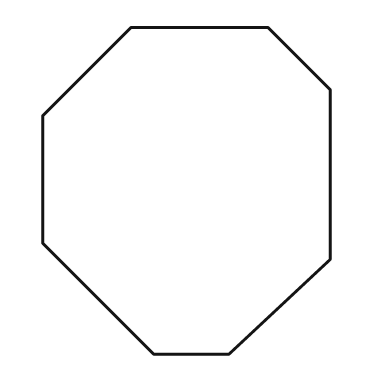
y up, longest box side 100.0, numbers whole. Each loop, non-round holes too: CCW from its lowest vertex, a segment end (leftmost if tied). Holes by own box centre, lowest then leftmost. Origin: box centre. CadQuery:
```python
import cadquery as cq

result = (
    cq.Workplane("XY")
    .moveTo(-10.0, -50.0)
    .lineTo(13.0, -50.0)
    .lineTo(44.0, -21.0)
    .lineTo(44.0, 31.0)
    .lineTo(25.0, 50.0)
    .lineTo(-17.0, 50.0)
    .lineTo(-44.0, 23.0)
    .lineTo(-44.0, -16.0)
    .close()
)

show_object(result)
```